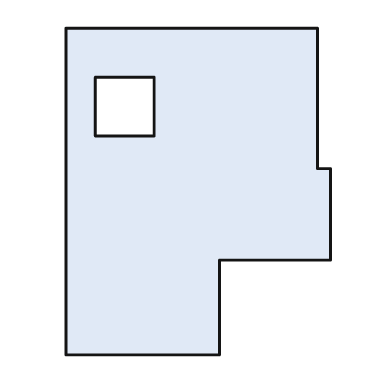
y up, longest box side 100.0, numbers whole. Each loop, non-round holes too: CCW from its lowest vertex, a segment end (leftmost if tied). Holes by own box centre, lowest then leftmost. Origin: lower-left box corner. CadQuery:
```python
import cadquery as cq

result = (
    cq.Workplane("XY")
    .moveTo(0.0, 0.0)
    .lineTo(47.0, 0.0)
    .lineTo(47.0, 29.0)
    .lineTo(81.0, 29.0)
    .lineTo(81.0, 57.0)
    .lineTo(77.0, 57.0)
    .lineTo(77.0, 100.0)
    .lineTo(0.0, 100.0)
    .close()
    .moveTo(9.0, 67.0)
    .lineTo(27.0, 67.0)
    .lineTo(27.0, 85.0)
    .lineTo(9.0, 85.0)
    .close()
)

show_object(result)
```